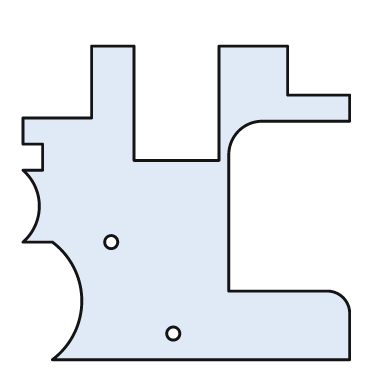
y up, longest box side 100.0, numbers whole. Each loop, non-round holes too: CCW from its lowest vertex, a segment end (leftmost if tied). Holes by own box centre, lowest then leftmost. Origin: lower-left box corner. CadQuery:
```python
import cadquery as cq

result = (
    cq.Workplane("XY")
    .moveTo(9.0, 0.0)
    .lineTo(100.0, 0.0)
    .lineTo(100.0, 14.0)
    .threePointArc((98.0, 19.0), (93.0, 21.0))
    .lineTo(63.0, 21.0)
    .lineTo(63.0, 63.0)
    .threePointArc((66.0, 70.0), (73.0, 73.0))
    .lineTo(100.0, 73.0)
    .lineTo(100.0, 81.0)
    .lineTo(81.0, 81.0)
    .lineTo(81.0, 96.0)
    .lineTo(60.0, 96.0)
    .lineTo(60.0, 61.0)
    .lineTo(34.0, 61.0)
    .lineTo(34.0, 96.0)
    .lineTo(21.0, 96.0)
    .lineTo(21.0, 74.0)
    .lineTo(0.0, 74.0)
    .lineTo(0.0, 66.0)
    .lineTo(6.0, 66.0)
    .lineTo(6.0, 58.0)
    .lineTo(0.0, 58.0)
    .threePointArc((5.0, 47.0), (0.0, 36.0))
    .lineTo(9.0, 36.0)
    .threePointArc((18.0, 18.0), (9.0, 0.0))
    .close()
    .moveTo(46.0, 8.0)
    .circle(2.0)
    .moveTo(27.0, 36.0)
    .circle(2.0)
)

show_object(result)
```